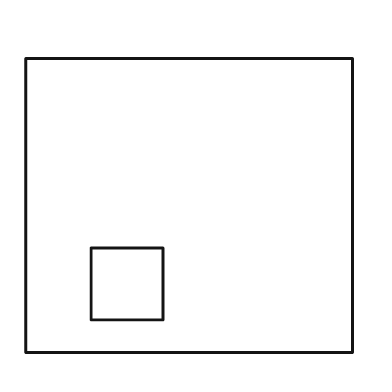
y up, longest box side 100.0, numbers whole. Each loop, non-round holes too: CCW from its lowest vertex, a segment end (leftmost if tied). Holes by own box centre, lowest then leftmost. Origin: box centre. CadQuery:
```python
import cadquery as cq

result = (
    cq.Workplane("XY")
    .moveTo(-50.0, -45.0)
    .lineTo(50.0, -45.0)
    .lineTo(50.0, 45.0)
    .lineTo(-50.0, 45.0)
    .close()
    .moveTo(-30.0, -35.0)
    .lineTo(-8.0, -35.0)
    .lineTo(-8.0, -13.0)
    .lineTo(-30.0, -13.0)
    .close()
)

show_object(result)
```